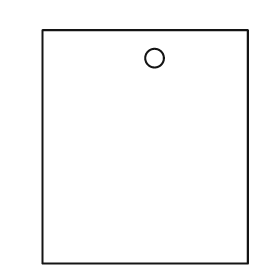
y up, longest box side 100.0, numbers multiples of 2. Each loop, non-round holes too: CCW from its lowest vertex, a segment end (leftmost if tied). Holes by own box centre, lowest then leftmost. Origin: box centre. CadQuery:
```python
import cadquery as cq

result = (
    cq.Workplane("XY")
    .moveTo(-44.0, -50.0)
    .lineTo(44.0, -50.0)
    .lineTo(44.0, 50.0)
    .lineTo(-44.0, 50.0)
    .close()
    .moveTo(4.0, 38.0)
    .circle(4.0)
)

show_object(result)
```